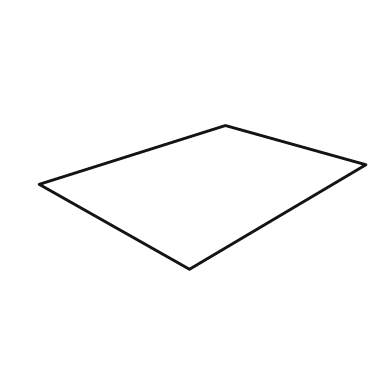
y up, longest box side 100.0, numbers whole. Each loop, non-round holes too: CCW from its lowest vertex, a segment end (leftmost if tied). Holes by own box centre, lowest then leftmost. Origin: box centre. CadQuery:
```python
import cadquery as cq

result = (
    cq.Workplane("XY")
    .moveTo(-4.0, -22.0)
    .lineTo(50.0, 10.0)
    .lineTo(7.0, 22.0)
    .lineTo(-50.0, 4.0)
    .close()
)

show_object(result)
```